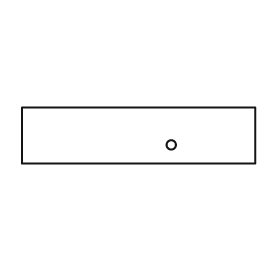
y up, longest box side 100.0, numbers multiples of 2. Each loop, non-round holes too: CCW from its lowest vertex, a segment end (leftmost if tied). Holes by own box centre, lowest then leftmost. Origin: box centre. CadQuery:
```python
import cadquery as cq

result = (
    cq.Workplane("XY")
    .moveTo(-50.0, -12.0)
    .lineTo(50.0, -12.0)
    .lineTo(50.0, 12.0)
    .lineTo(-50.0, 12.0)
    .close()
    .moveTo(14.0, -4.0)
    .circle(2.0)
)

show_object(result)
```